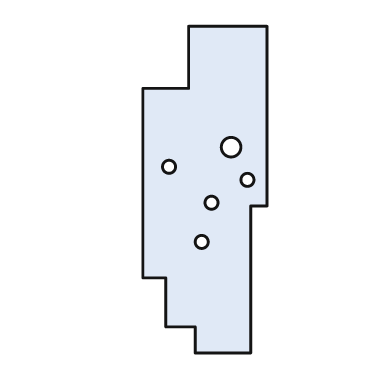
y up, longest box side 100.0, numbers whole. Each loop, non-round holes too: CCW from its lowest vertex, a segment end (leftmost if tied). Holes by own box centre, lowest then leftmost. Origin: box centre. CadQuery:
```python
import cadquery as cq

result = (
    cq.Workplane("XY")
    .moveTo(-3.0, -50.0)
    .lineTo(14.0, -50.0)
    .lineTo(14.0, -5.0)
    .lineTo(19.0, -5.0)
    .lineTo(19.0, 50.0)
    .lineTo(-5.0, 50.0)
    .lineTo(-5.0, 31.0)
    .lineTo(-19.0, 31.0)
    .lineTo(-19.0, -27.0)
    .lineTo(-12.0, -27.0)
    .lineTo(-12.0, -42.0)
    .lineTo(-3.0, -42.0)
    .close()
    .moveTo(-1.0, -16.0)
    .circle(2.0)
    .moveTo(2.0, -4.0)
    .circle(2.0)
    .moveTo(13.0, 3.0)
    .circle(2.0)
    .moveTo(-11.0, 7.0)
    .circle(2.0)
    .moveTo(8.0, 13.0)
    .circle(3.0)
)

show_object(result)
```